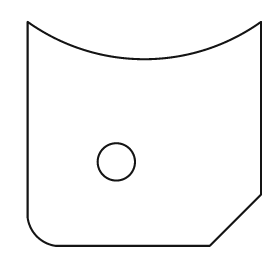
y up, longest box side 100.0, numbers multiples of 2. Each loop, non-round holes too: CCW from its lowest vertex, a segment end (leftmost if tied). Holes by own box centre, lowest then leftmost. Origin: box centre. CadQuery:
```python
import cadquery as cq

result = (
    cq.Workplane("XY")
    .moveTo(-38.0, -48.0)
    .lineTo(28.0, -48.0)
    .lineTo(50.0, -26.0)
    .lineTo(50.0, 48.0)
    .threePointArc((0.0, 32.0), (-50.0, 48.0))
    .lineTo(-50.0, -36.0)
    .threePointArc((-46.0, -44.0), (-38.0, -48.0))
    .close()
    .moveTo(-12.0, -12.0)
    .circle(8.0)
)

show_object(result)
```